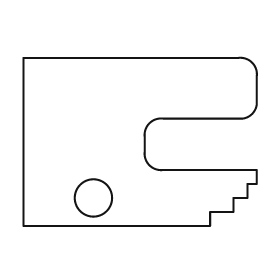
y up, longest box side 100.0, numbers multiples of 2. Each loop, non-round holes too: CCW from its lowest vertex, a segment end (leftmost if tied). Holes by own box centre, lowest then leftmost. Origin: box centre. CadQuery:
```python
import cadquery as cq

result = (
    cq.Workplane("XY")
    .moveTo(-50.0, -36.0)
    .lineTo(30.0, -36.0)
    .lineTo(30.0, -30.0)
    .lineTo(40.0, -30.0)
    .lineTo(40.0, -24.0)
    .lineTo(46.0, -24.0)
    .lineTo(46.0, -18.0)
    .lineTo(50.0, -18.0)
    .lineTo(50.0, -12.0)
    .lineTo(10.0, -12.0)
    .threePointArc((4.0, -10.0), (2.0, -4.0))
    .lineTo(2.0, 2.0)
    .threePointArc((4.0, 8.0), (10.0, 10.0))
    .lineTo(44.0, 10.0)
    .threePointArc((48.0, 12.0), (50.0, 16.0))
    .lineTo(50.0, 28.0)
    .threePointArc((48.0, 34.0), (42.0, 36.0))
    .lineTo(-50.0, 36.0)
    .close()
    .moveTo(-20.0, -24.0)
    .circle(8.0)
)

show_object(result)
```